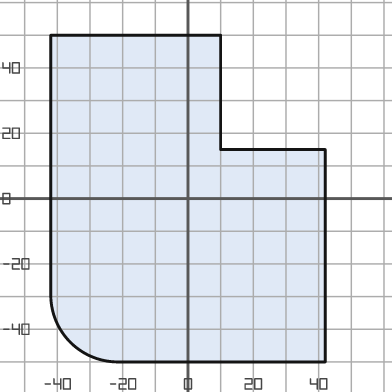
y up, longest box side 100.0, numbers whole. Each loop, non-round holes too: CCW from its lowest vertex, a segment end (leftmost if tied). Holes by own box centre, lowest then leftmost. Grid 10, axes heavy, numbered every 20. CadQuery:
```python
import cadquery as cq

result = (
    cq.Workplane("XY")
    .moveTo(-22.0, -50.0)
    .lineTo(42.0, -50.0)
    .lineTo(42.0, 15.0)
    .lineTo(10.0, 15.0)
    .lineTo(10.0, 50.0)
    .lineTo(-42.0, 50.0)
    .lineTo(-42.0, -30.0)
    .threePointArc((-36.0, -44.0), (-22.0, -50.0))
    .close()
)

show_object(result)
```